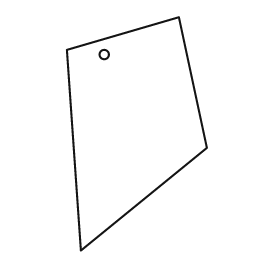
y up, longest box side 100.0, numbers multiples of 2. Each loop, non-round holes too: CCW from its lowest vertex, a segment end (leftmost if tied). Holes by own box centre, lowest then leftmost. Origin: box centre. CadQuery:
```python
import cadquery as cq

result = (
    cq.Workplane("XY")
    .moveTo(-24.0, -50.0)
    .lineTo(30.0, -6.0)
    .lineTo(18.0, 50.0)
    .lineTo(-30.0, 36.0)
    .close()
    .moveTo(-14.0, 34.0)
    .circle(2.0)
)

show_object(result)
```